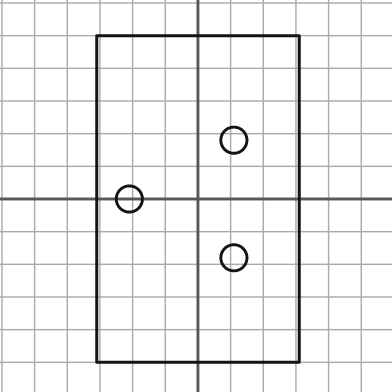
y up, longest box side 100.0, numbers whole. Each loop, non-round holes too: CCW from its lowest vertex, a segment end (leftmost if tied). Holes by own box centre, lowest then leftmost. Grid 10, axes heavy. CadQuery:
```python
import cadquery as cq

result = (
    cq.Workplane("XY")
    .moveTo(-31.0, -50.0)
    .lineTo(31.0, -50.0)
    .lineTo(31.0, 50.0)
    .lineTo(-31.0, 50.0)
    .close()
    .moveTo(11.0, -18.0)
    .circle(4.0)
    .moveTo(-21.0, 0.0)
    .circle(4.0)
    .moveTo(11.0, 18.0)
    .circle(4.0)
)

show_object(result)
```